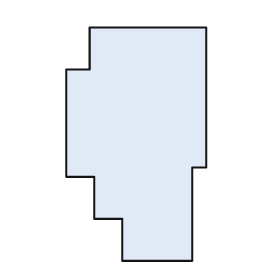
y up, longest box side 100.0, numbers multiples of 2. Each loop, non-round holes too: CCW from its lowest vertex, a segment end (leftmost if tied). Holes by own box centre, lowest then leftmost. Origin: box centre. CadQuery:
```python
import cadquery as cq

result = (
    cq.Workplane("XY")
    .moveTo(-6.0, -50.0)
    .lineTo(24.0, -50.0)
    .lineTo(24.0, -10.0)
    .lineTo(30.0, -10.0)
    .lineTo(30.0, 50.0)
    .lineTo(-20.0, 50.0)
    .lineTo(-20.0, 32.0)
    .lineTo(-30.0, 32.0)
    .lineTo(-30.0, -14.0)
    .lineTo(-18.0, -14.0)
    .lineTo(-18.0, -32.0)
    .lineTo(-6.0, -32.0)
    .close()
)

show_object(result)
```